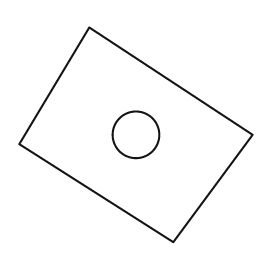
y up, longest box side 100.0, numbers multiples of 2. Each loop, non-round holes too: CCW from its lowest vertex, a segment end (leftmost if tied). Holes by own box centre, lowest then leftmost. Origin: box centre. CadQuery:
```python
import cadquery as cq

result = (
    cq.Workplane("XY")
    .moveTo(16.0, -46.0)
    .lineTo(50.0, 0.0)
    .lineTo(-20.0, 46.0)
    .lineTo(-50.0, -4.0)
    .close()
    .moveTo(0.0, 0.0)
    .circle(10.0)
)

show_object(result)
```